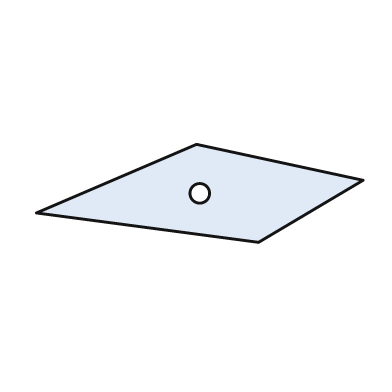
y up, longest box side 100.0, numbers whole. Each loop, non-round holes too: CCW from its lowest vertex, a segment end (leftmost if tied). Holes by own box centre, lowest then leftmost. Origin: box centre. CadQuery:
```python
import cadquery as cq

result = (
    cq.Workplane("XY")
    .moveTo(18.0, -15.0)
    .lineTo(50.0, 4.0)
    .lineTo(-1.0, 15.0)
    .lineTo(-50.0, -6.0)
    .close()
    .moveTo(0.0, 0.0)
    .circle(3.0)
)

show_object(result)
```